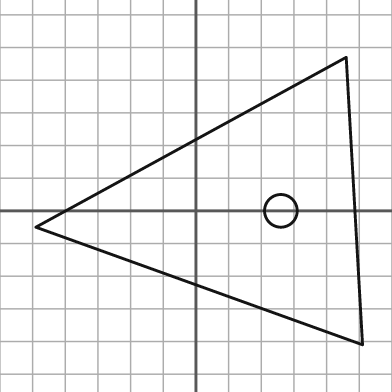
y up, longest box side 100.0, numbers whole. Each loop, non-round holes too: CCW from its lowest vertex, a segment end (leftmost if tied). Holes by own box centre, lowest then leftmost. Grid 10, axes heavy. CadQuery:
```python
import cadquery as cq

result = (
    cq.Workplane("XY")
    .moveTo(51.0, -41.0)
    .lineTo(46.0, 47.0)
    .lineTo(-49.0, -5.0)
    .close()
    .moveTo(26.0, 0.0)
    .circle(5.0)
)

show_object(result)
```